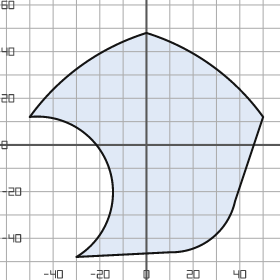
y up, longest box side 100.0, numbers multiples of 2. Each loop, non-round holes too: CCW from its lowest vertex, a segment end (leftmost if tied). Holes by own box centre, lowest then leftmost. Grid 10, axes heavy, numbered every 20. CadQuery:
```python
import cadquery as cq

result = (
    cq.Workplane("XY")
    .moveTo(-30.0, -48.0)
    .lineTo(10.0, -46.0)
    .threePointArc((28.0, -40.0), (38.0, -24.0))
    .lineTo(50.0, 12.0)
    .threePointArc((28.0, 34.0), (0.0, 48.0))
    .threePointArc((-28.0, 34.0), (-50.0, 12.0))
    .threePointArc((-16.0, -10.0), (-30.0, -48.0))
    .close()
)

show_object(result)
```